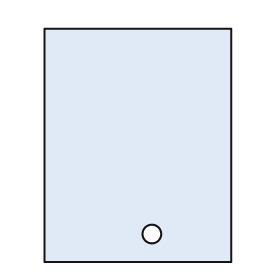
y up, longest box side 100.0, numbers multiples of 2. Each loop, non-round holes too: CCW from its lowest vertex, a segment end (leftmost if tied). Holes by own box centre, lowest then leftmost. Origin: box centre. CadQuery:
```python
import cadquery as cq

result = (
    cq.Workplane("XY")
    .moveTo(-40.0, -50.0)
    .lineTo(40.0, -50.0)
    .lineTo(40.0, 50.0)
    .lineTo(-40.0, 50.0)
    .close()
    .moveTo(6.0, -38.0)
    .circle(4.0)
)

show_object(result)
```